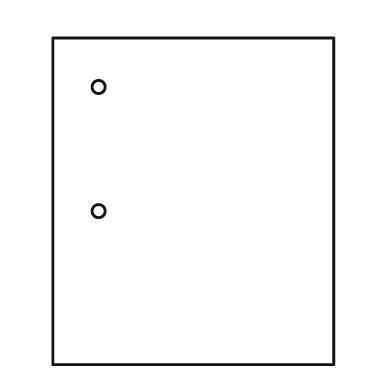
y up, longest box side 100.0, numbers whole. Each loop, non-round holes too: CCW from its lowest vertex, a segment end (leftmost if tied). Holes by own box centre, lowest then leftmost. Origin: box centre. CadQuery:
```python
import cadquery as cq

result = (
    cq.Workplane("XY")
    .moveTo(-43.0, -50.0)
    .lineTo(43.0, -50.0)
    .lineTo(43.0, 50.0)
    .lineTo(-43.0, 50.0)
    .close()
    .moveTo(-29.0, -3.0)
    .circle(2.0)
    .moveTo(-29.0, 35.0)
    .circle(2.0)
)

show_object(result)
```